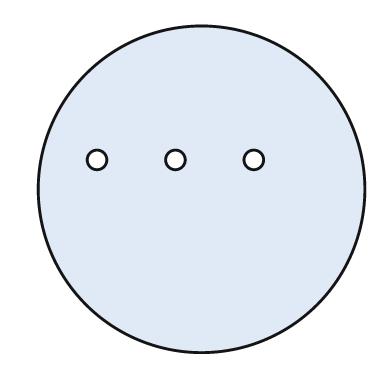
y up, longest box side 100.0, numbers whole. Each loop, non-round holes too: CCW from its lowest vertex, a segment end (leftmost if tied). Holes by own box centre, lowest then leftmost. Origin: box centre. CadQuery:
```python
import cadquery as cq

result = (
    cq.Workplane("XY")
    .moveTo(0.0, 0.0)
    .circle(50.0)
    .moveTo(-32.0, 9.0)
    .circle(3.0)
    .moveTo(-8.0, 9.0)
    .circle(3.0)
    .moveTo(16.0, 9.0)
    .circle(3.0)
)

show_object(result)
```